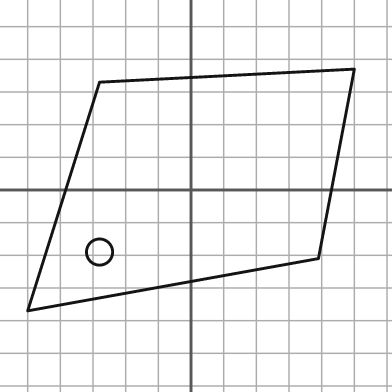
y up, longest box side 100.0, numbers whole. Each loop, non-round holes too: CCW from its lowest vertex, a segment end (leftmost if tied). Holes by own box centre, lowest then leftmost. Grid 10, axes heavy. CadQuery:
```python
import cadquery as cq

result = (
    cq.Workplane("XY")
    .moveTo(-50.0, -37.0)
    .lineTo(39.0, -21.0)
    .lineTo(50.0, 37.0)
    .lineTo(-28.0, 33.0)
    .close()
    .moveTo(-28.0, -19.0)
    .circle(4.0)
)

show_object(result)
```